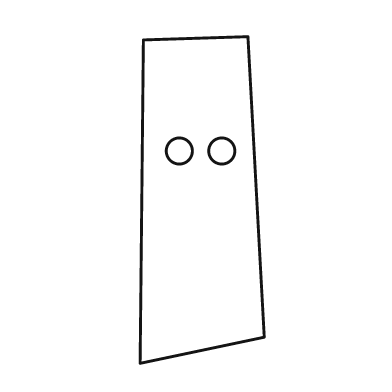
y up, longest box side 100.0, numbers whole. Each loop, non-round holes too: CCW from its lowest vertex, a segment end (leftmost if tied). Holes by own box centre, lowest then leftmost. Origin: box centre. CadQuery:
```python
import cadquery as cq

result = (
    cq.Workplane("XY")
    .moveTo(-19.0, -50.0)
    .lineTo(19.0, -42.0)
    .lineTo(14.0, 50.0)
    .lineTo(-18.0, 49.0)
    .close()
    .moveTo(-7.0, 15.0)
    .circle(4.0)
    .moveTo(6.0, 15.0)
    .circle(4.0)
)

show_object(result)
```